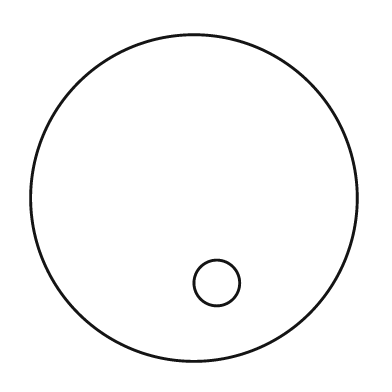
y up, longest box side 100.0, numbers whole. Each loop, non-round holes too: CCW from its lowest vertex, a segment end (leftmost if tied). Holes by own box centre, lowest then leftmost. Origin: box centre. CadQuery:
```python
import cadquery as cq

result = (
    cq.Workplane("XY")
    .moveTo(0.0, 0.0)
    .circle(50.0)
    .moveTo(7.0, -26.0)
    .circle(7.0)
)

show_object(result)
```